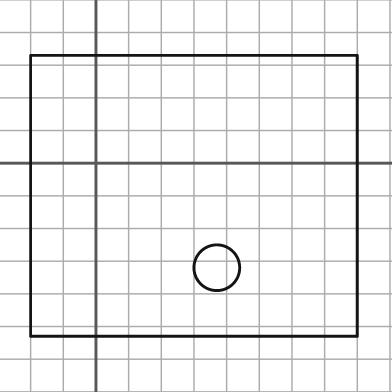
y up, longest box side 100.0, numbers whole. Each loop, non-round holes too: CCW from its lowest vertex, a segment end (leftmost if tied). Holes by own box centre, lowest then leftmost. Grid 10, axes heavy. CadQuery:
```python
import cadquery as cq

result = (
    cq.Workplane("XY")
    .moveTo(-20.0, -53.0)
    .lineTo(80.0, -53.0)
    .lineTo(80.0, 33.0)
    .lineTo(-20.0, 33.0)
    .close()
    .moveTo(37.0, -32.0)
    .circle(7.0)
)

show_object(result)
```